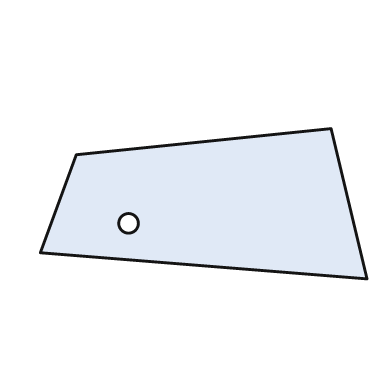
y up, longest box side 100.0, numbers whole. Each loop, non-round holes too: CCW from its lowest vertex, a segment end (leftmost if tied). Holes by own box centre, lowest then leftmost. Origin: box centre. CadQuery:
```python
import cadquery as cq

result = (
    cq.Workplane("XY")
    .moveTo(50.0, -23.0)
    .lineTo(39.0, 23.0)
    .lineTo(-39.0, 15.0)
    .lineTo(-50.0, -15.0)
    .close()
    .moveTo(-23.0, -6.0)
    .circle(3.0)
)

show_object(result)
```